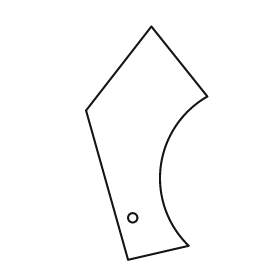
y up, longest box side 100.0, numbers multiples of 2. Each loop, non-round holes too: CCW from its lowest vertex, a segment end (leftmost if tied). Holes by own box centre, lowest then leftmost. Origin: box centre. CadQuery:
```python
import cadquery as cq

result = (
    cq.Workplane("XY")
    .moveTo(-8.0, -50.0)
    .lineTo(18.0, -44.0)
    .threePointArc((6.0, -10.0), (26.0, 20.0))
    .lineTo(2.0, 50.0)
    .lineTo(-26.0, 14.0)
    .close()
    .moveTo(-6.0, -32.0)
    .circle(2.0)
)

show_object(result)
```